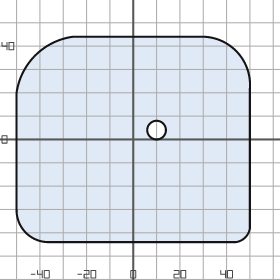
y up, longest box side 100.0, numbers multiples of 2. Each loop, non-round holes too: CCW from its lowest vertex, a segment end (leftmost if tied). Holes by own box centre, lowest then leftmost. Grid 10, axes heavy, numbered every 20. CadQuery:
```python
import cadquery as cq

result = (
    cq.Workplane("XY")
    .moveTo(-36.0, -44.0)
    .lineTo(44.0, -44.0)
    .threePointArc((48.0, -42.0), (50.0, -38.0))
    .lineTo(50.0, 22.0)
    .threePointArc((44.0, 38.0), (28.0, 44.0))
    .lineTo(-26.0, 44.0)
    .threePointArc((-42.0, 36.0), (-50.0, 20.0))
    .lineTo(-50.0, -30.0)
    .threePointArc((-46.0, -40.0), (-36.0, -44.0))
    .close()
    .moveTo(10.0, 4.0)
    .circle(4.0)
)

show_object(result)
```